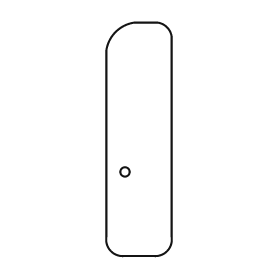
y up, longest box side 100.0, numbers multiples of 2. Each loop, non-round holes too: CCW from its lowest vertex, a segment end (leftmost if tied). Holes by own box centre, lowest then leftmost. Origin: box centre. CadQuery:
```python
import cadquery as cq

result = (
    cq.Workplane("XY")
    .moveTo(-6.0, -50.0)
    .lineTo(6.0, -50.0)
    .threePointArc((12.0, -48.0), (14.0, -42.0))
    .lineTo(14.0, 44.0)
    .threePointArc((12.0, 48.0), (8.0, 50.0))
    .lineTo(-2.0, 50.0)
    .threePointArc((-10.0, 46.0), (-14.0, 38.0))
    .lineTo(-14.0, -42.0)
    .threePointArc((-12.0, -48.0), (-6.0, -50.0))
    .close()
    .moveTo(-6.0, -14.0)
    .circle(2.0)
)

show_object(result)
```